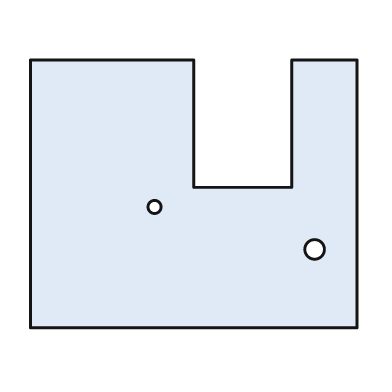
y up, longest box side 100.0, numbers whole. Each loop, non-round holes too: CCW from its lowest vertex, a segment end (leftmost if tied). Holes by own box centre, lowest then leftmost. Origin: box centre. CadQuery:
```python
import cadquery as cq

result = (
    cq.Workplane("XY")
    .moveTo(-50.0, -41.0)
    .lineTo(50.0, -41.0)
    .lineTo(50.0, 41.0)
    .lineTo(30.0, 41.0)
    .lineTo(30.0, 2.0)
    .lineTo(0.0, 2.0)
    .lineTo(0.0, 41.0)
    .lineTo(-50.0, 41.0)
    .close()
    .moveTo(37.0, -17.0)
    .circle(3.0)
    .moveTo(-12.0, -4.0)
    .circle(2.0)
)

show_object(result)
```